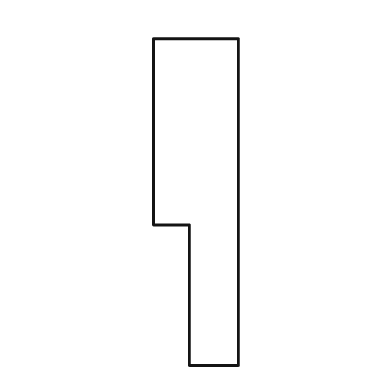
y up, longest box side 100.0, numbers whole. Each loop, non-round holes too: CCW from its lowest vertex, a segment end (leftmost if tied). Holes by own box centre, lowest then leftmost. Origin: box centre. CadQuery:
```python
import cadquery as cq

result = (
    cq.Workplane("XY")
    .moveTo(-2.0, -50.0)
    .lineTo(13.0, -50.0)
    .lineTo(13.0, 50.0)
    .lineTo(-13.0, 50.0)
    .lineTo(-13.0, -7.0)
    .lineTo(-2.0, -7.0)
    .close()
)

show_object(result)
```